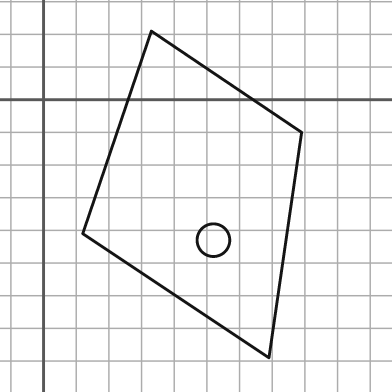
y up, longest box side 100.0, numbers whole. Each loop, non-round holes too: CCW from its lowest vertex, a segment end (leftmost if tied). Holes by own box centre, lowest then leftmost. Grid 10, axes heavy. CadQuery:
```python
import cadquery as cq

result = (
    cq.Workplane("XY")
    .moveTo(69.0, -79.0)
    .lineTo(79.0, -10.0)
    .lineTo(33.0, 21.0)
    .lineTo(12.0, -41.0)
    .close()
    .moveTo(52.0, -43.0)
    .circle(5.0)
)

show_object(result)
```